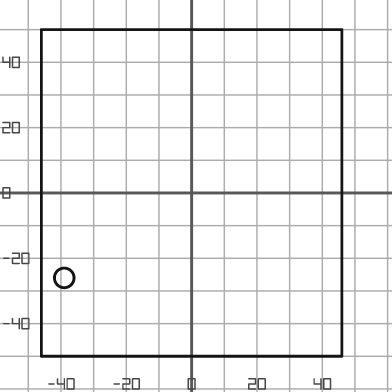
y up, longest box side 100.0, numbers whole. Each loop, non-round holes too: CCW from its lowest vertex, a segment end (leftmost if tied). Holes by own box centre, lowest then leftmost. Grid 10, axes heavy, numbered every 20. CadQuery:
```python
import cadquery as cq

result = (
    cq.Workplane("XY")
    .moveTo(-46.0, -50.0)
    .lineTo(46.0, -50.0)
    .lineTo(46.0, 50.0)
    .lineTo(-46.0, 50.0)
    .close()
    .moveTo(-39.0, -26.0)
    .circle(3.0)
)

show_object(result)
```